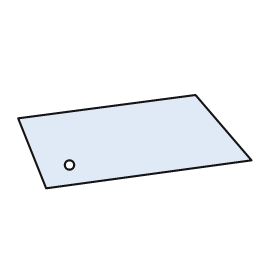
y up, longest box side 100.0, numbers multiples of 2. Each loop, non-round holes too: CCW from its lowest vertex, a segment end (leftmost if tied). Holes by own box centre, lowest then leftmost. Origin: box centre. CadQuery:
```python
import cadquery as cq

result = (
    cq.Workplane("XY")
    .moveTo(-38.0, -20.0)
    .lineTo(50.0, -8.0)
    .lineTo(26.0, 20.0)
    .lineTo(-50.0, 10.0)
    .close()
    .moveTo(-28.0, -10.0)
    .circle(2.0)
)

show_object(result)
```